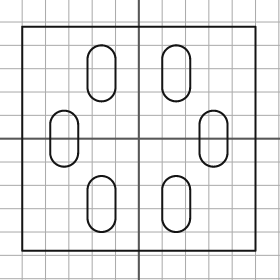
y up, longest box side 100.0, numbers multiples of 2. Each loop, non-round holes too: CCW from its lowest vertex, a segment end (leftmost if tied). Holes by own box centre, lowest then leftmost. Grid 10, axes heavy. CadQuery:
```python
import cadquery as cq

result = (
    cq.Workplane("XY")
    .moveTo(-50.0, -48.0)
    .lineTo(50.0, -48.0)
    .lineTo(50.0, 48.0)
    .lineTo(-50.0, 48.0)
    .close()
    .moveTo(-22.0, -34.0)
    .threePointArc((-16.0, -40.0), (-10.0, -34.0))
    .lineTo(-10.0, -22.0)
    .threePointArc((-16.0, -16.0), (-22.0, -22.0))
    .close()
    .moveTo(10.0, -34.0)
    .threePointArc((16.0, -40.0), (22.0, -34.0))
    .lineTo(22.0, -22.0)
    .threePointArc((16.0, -16.0), (10.0, -22.0))
    .close()
    .moveTo(-38.0, -6.0)
    .threePointArc((-32.0, -12.0), (-26.0, -6.0))
    .lineTo(-26.0, 6.0)
    .threePointArc((-32.0, 12.0), (-38.0, 6.0))
    .close()
    .moveTo(26.0, -6.0)
    .threePointArc((32.0, -12.0), (38.0, -6.0))
    .lineTo(38.0, 6.0)
    .threePointArc((32.0, 12.0), (26.0, 6.0))
    .close()
    .moveTo(-22.0, 22.0)
    .threePointArc((-16.0, 16.0), (-10.0, 22.0))
    .lineTo(-10.0, 34.0)
    .threePointArc((-16.0, 40.0), (-22.0, 34.0))
    .close()
    .moveTo(10.0, 22.0)
    .threePointArc((16.0, 16.0), (22.0, 22.0))
    .lineTo(22.0, 34.0)
    .threePointArc((16.0, 40.0), (10.0, 34.0))
    .close()
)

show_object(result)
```